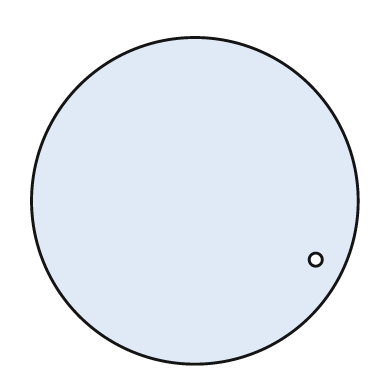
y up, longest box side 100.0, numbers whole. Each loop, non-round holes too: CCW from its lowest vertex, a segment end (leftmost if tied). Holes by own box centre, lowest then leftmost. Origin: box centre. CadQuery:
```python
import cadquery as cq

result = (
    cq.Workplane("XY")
    .moveTo(0.0, 0.0)
    .circle(50.0)
    .moveTo(37.0, -18.0)
    .circle(2.0)
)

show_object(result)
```